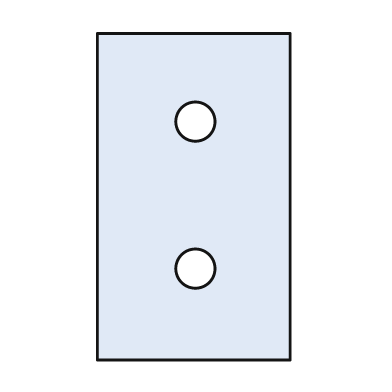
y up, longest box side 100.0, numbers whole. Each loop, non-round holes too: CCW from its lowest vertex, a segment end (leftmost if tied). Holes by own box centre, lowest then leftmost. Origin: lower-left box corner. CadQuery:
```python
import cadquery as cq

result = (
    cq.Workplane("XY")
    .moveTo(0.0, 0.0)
    .lineTo(59.0, 0.0)
    .lineTo(59.0, 100.0)
    .lineTo(0.0, 100.0)
    .close()
    .moveTo(30.0, 28.0)
    .circle(6.0)
    .moveTo(30.0, 73.0)
    .circle(6.0)
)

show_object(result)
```